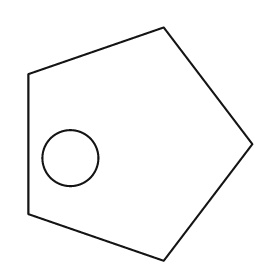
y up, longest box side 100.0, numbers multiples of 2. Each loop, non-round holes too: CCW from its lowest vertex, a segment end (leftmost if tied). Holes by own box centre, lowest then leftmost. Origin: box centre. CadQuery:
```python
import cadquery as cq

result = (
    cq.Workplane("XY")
    .moveTo(10.0, -50.0)
    .lineTo(48.0, 0.0)
    .lineTo(10.0, 50.0)
    .lineTo(-48.0, 30.0)
    .lineTo(-48.0, -30.0)
    .close()
    .moveTo(-30.0, -6.0)
    .circle(12.0)
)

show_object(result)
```